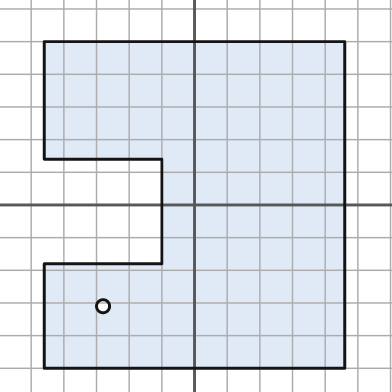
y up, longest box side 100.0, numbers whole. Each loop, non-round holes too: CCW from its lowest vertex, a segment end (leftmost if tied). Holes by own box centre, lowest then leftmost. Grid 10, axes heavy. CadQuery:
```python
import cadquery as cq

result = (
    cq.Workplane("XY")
    .moveTo(-46.0, -50.0)
    .lineTo(46.0, -50.0)
    .lineTo(46.0, 50.0)
    .lineTo(-46.0, 50.0)
    .lineTo(-46.0, 14.0)
    .lineTo(-10.0, 14.0)
    .lineTo(-10.0, -18.0)
    .lineTo(-46.0, -18.0)
    .close()
    .moveTo(-28.0, -31.0)
    .circle(2.0)
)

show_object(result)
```